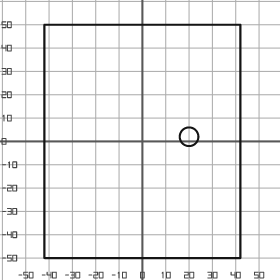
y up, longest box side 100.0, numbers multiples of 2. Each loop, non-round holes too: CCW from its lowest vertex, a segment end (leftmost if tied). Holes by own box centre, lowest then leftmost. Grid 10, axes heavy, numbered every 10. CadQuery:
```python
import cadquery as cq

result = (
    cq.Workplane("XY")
    .moveTo(-42.0, -50.0)
    .lineTo(42.0, -50.0)
    .lineTo(42.0, 50.0)
    .lineTo(-42.0, 50.0)
    .close()
    .moveTo(20.0, 2.0)
    .circle(4.0)
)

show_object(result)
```